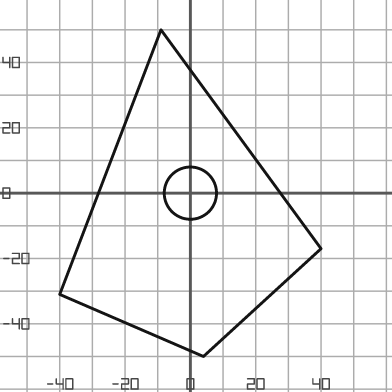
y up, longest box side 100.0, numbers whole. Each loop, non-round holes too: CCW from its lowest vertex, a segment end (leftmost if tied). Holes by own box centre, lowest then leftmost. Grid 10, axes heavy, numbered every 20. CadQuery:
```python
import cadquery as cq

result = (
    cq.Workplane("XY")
    .moveTo(4.0, -50.0)
    .lineTo(40.0, -17.0)
    .lineTo(-9.0, 50.0)
    .lineTo(-40.0, -31.0)
    .close()
    .moveTo(0.0, 0.0)
    .circle(8.0)
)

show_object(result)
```